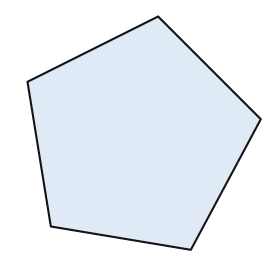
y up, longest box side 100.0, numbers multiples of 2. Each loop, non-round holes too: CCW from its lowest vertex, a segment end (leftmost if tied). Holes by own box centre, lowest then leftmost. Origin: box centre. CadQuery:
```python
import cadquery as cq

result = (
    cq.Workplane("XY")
    .moveTo(20.0, -50.0)
    .lineTo(50.0, 6.0)
    .lineTo(6.0, 50.0)
    .lineTo(-50.0, 22.0)
    .lineTo(-40.0, -40.0)
    .close()
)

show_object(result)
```